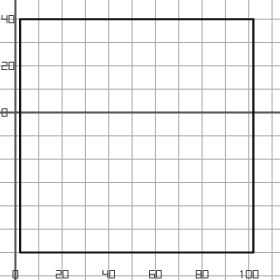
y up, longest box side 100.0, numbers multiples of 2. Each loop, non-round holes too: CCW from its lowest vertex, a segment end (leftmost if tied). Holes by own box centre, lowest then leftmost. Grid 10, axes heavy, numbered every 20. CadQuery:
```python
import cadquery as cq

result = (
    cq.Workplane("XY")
    .moveTo(2.0, -60.0)
    .lineTo(102.0, -60.0)
    .lineTo(102.0, 40.0)
    .lineTo(2.0, 40.0)
    .close()
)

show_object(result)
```